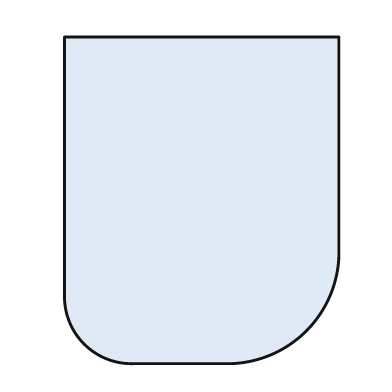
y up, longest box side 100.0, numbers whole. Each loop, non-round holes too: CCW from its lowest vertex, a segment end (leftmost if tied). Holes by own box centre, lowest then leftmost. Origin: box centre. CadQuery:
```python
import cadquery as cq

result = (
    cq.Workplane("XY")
    .moveTo(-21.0, -50.0)
    .lineTo(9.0, -50.0)
    .threePointArc((32.0, -40.0), (42.0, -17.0))
    .lineTo(42.0, 50.0)
    .lineTo(-42.0, 50.0)
    .lineTo(-42.0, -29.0)
    .threePointArc((-36.0, -44.0), (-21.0, -50.0))
    .close()
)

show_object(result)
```